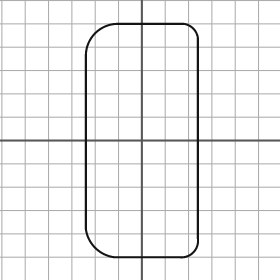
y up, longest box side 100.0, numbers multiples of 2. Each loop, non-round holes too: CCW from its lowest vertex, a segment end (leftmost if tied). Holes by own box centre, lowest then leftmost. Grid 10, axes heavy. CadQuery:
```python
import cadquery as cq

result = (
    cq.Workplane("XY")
    .moveTo(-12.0, -50.0)
    .lineTo(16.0, -50.0)
    .threePointArc((22.0, -48.0), (24.0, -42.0))
    .lineTo(24.0, 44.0)
    .threePointArc((22.0, 48.0), (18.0, 50.0))
    .lineTo(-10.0, 50.0)
    .threePointArc((-20.0, 46.0), (-24.0, 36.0))
    .lineTo(-24.0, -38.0)
    .threePointArc((-20.0, -46.0), (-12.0, -50.0))
    .close()
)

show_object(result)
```